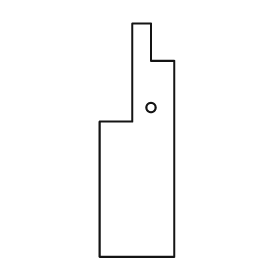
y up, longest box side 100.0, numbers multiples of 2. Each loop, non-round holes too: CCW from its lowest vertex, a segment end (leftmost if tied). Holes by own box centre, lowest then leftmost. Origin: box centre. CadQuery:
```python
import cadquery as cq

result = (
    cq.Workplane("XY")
    .moveTo(-16.0, -50.0)
    .lineTo(16.0, -50.0)
    .lineTo(16.0, 34.0)
    .lineTo(6.0, 34.0)
    .lineTo(6.0, 50.0)
    .lineTo(-2.0, 50.0)
    .lineTo(-2.0, 8.0)
    .lineTo(-16.0, 8.0)
    .close()
    .moveTo(6.0, 14.0)
    .circle(2.0)
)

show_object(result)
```